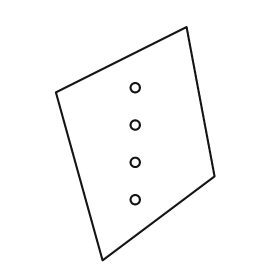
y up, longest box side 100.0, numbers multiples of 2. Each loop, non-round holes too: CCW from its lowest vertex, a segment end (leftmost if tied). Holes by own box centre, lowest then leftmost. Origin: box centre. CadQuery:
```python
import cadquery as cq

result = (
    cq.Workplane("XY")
    .moveTo(-14.0, -50.0)
    .lineTo(34.0, -14.0)
    .lineTo(22.0, 50.0)
    .lineTo(-34.0, 22.0)
    .close()
    .moveTo(0.0, -24.0)
    .circle(2.0)
    .moveTo(0.0, -8.0)
    .circle(2.0)
    .moveTo(0.0, 8.0)
    .circle(2.0)
    .moveTo(0.0, 24.0)
    .circle(2.0)
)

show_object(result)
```